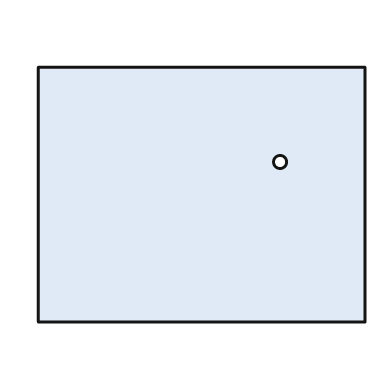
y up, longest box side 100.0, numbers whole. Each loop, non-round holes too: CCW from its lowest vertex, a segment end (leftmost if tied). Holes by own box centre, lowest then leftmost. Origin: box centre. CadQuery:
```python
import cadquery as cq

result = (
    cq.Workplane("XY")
    .moveTo(-50.0, -39.0)
    .lineTo(50.0, -39.0)
    .lineTo(50.0, 39.0)
    .lineTo(-50.0, 39.0)
    .close()
    .moveTo(24.0, 10.0)
    .circle(2.0)
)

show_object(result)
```